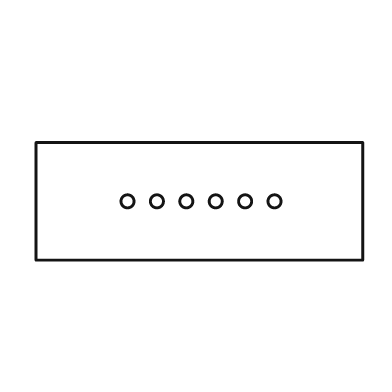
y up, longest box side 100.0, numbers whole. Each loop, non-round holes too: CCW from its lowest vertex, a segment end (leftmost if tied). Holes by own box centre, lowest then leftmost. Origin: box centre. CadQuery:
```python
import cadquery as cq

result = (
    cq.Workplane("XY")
    .moveTo(-50.0, -18.0)
    .lineTo(50.0, -18.0)
    .lineTo(50.0, 18.0)
    .lineTo(-50.0, 18.0)
    .close()
    .moveTo(-22.0, 0.0)
    .circle(2.0)
    .moveTo(-13.0, 0.0)
    .circle(2.0)
    .moveTo(-4.0, 0.0)
    .circle(2.0)
    .moveTo(5.0, 0.0)
    .circle(2.0)
    .moveTo(14.0, 0.0)
    .circle(2.0)
    .moveTo(23.0, 0.0)
    .circle(2.0)
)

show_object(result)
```